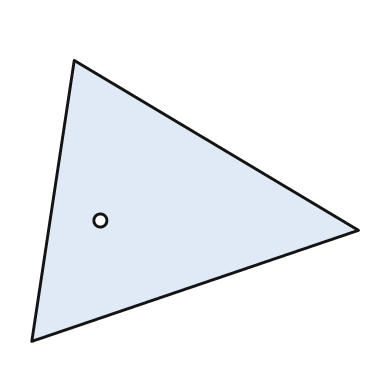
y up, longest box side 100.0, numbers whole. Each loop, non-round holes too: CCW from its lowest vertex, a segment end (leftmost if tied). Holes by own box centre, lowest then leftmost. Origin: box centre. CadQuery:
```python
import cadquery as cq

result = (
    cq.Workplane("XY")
    .moveTo(-50.0, -43.0)
    .lineTo(50.0, -9.0)
    .lineTo(-37.0, 43.0)
    .close()
    .moveTo(-29.0, -6.0)
    .circle(2.0)
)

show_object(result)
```